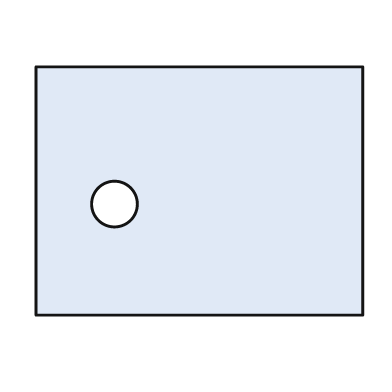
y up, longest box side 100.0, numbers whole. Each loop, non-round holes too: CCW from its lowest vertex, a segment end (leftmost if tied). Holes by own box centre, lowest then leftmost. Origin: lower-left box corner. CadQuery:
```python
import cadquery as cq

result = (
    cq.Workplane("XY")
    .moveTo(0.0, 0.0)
    .lineTo(100.0, 0.0)
    .lineTo(100.0, 76.0)
    .lineTo(0.0, 76.0)
    .close()
    .moveTo(24.0, 34.0)
    .circle(7.0)
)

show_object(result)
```